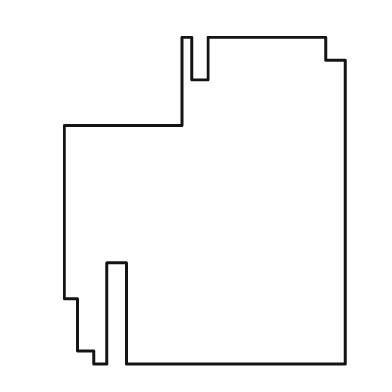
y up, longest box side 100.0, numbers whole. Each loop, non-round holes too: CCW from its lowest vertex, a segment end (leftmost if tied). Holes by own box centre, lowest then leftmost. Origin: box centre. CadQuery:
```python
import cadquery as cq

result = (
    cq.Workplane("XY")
    .moveTo(-34.0, -50.0)
    .lineTo(-30.0, -50.0)
    .lineTo(-30.0, -19.0)
    .lineTo(-24.0, -19.0)
    .lineTo(-24.0, -50.0)
    .lineTo(43.0, -50.0)
    .lineTo(43.0, 43.0)
    .lineTo(37.0, 43.0)
    .lineTo(37.0, 50.0)
    .lineTo(1.0, 50.0)
    .lineTo(1.0, 37.0)
    .lineTo(-4.0, 37.0)
    .lineTo(-4.0, 50.0)
    .lineTo(-7.0, 50.0)
    .lineTo(-7.0, 23.0)
    .lineTo(-43.0, 23.0)
    .lineTo(-43.0, -30.0)
    .lineTo(-39.0, -30.0)
    .lineTo(-39.0, -46.0)
    .lineTo(-34.0, -46.0)
    .close()
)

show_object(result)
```